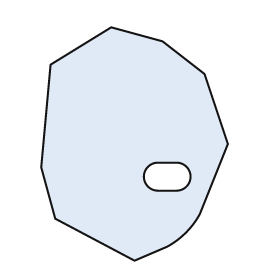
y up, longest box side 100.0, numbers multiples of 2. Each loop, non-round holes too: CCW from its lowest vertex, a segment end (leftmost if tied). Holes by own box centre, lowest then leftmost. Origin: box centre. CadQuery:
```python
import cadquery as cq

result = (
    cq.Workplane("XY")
    .moveTo(0.0, -50.0)
    .lineTo(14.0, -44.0)
    .threePointArc((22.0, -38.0), (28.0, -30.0))
    .lineTo(40.0, 0.0)
    .lineTo(30.0, 30.0)
    .lineTo(12.0, 44.0)
    .lineTo(-10.0, 50.0)
    .lineTo(-36.0, 34.0)
    .lineTo(-40.0, -10.0)
    .lineTo(-34.0, -32.0)
    .close()
    .moveTo(10.0, -20.0)
    .lineTo(18.0, -20.0)
    .threePointArc((24.0, -14.0), (18.0, -8.0))
    .lineTo(10.0, -8.0)
    .threePointArc((4.0, -14.0), (10.0, -20.0))
    .close()
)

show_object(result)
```